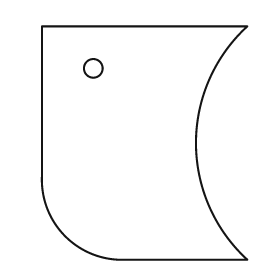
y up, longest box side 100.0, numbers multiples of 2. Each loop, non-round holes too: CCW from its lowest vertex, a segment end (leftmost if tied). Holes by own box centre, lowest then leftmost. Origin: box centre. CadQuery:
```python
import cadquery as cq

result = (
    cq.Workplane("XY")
    .moveTo(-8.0, -50.0)
    .lineTo(44.0, -50.0)
    .threePointArc((22.0, 0.0), (44.0, 50.0))
    .lineTo(-44.0, 50.0)
    .lineTo(-44.0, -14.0)
    .threePointArc((-34.0, -40.0), (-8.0, -50.0))
    .close()
    .moveTo(-22.0, 32.0)
    .circle(4.0)
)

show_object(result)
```